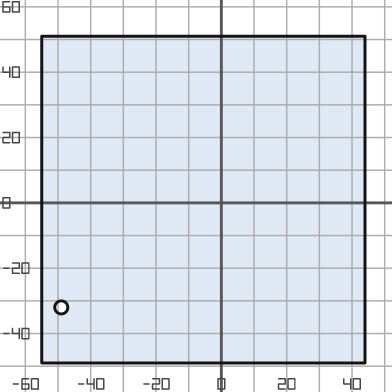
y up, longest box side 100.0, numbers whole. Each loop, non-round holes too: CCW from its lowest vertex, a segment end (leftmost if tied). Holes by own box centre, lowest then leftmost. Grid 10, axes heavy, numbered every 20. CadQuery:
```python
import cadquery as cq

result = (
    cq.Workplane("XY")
    .moveTo(-55.0, -49.0)
    .lineTo(44.0, -49.0)
    .lineTo(44.0, 51.0)
    .lineTo(-55.0, 51.0)
    .close()
    .moveTo(-49.0, -32.0)
    .circle(2.0)
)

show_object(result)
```